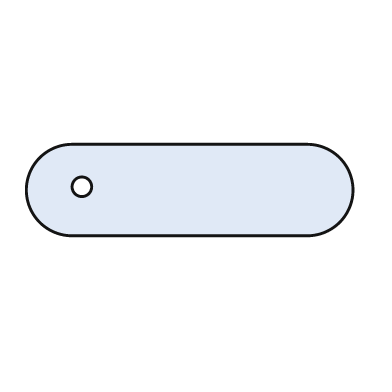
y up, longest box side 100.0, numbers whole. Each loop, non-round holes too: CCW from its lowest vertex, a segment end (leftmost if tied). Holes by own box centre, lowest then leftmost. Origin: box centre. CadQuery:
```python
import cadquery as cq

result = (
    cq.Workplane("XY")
    .moveTo(-36.0, -14.0)
    .lineTo(36.0, -14.0)
    .threePointArc((50.0, 0.0), (36.0, 14.0))
    .lineTo(-36.0, 14.0)
    .threePointArc((-50.0, 0.0), (-36.0, -14.0))
    .close()
    .moveTo(-33.0, 1.0)
    .circle(3.0)
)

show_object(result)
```